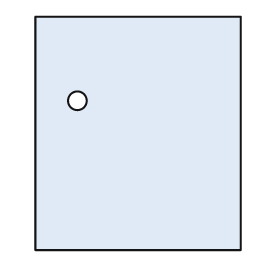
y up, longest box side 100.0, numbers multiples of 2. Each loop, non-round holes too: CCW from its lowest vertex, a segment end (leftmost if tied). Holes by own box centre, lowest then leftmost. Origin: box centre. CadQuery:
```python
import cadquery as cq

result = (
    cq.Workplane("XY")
    .moveTo(-44.0, -50.0)
    .lineTo(44.0, -50.0)
    .lineTo(44.0, 50.0)
    .lineTo(-44.0, 50.0)
    .close()
    .moveTo(-26.0, 14.0)
    .circle(4.0)
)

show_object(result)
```